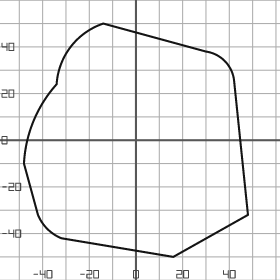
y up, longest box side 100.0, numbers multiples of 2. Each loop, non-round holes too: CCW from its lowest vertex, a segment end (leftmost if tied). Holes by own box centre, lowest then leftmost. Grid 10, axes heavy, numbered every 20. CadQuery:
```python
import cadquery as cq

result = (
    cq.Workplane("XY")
    .moveTo(16.0, -50.0)
    .lineTo(48.0, -32.0)
    .lineTo(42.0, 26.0)
    .threePointArc((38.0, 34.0), (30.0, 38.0))
    .lineTo(-14.0, 50.0)
    .threePointArc((-28.0, 40.0), (-34.0, 24.0))
    .threePointArc((-44.0, 8.0), (-48.0, -10.0))
    .lineTo(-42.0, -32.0)
    .threePointArc((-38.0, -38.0), (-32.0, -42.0))
    .close()
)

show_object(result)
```